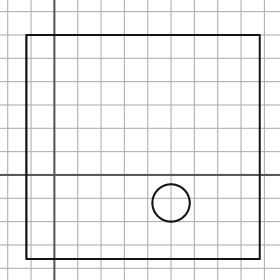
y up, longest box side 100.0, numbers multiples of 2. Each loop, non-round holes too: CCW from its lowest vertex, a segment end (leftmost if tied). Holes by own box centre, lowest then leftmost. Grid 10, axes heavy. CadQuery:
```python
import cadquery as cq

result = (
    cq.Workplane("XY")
    .moveTo(-12.0, -36.0)
    .lineTo(88.0, -36.0)
    .lineTo(88.0, 60.0)
    .lineTo(-12.0, 60.0)
    .close()
    .moveTo(50.0, -12.0)
    .circle(8.0)
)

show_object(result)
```